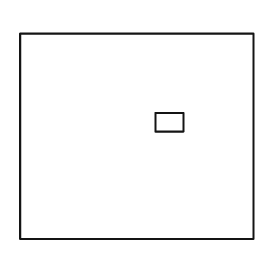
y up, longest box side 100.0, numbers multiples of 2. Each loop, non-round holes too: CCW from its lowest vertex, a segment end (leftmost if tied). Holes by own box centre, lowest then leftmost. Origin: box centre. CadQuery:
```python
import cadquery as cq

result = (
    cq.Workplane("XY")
    .moveTo(-50.0, -44.0)
    .lineTo(50.0, -44.0)
    .lineTo(50.0, 44.0)
    .lineTo(-50.0, 44.0)
    .close()
    .moveTo(8.0, 2.0)
    .lineTo(20.0, 2.0)
    .lineTo(20.0, 10.0)
    .lineTo(8.0, 10.0)
    .close()
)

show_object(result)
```